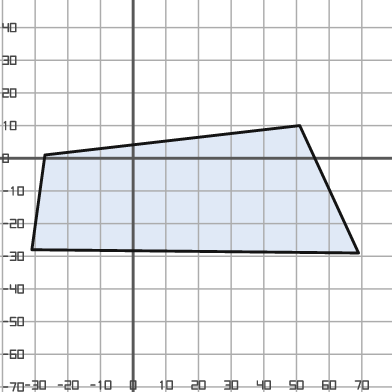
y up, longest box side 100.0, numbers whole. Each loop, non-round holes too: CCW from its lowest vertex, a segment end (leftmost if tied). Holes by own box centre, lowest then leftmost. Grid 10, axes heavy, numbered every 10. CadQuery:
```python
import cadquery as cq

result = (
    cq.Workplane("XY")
    .moveTo(69.0, -29.0)
    .lineTo(51.0, 10.0)
    .lineTo(-27.0, 1.0)
    .lineTo(-31.0, -28.0)
    .close()
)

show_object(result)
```